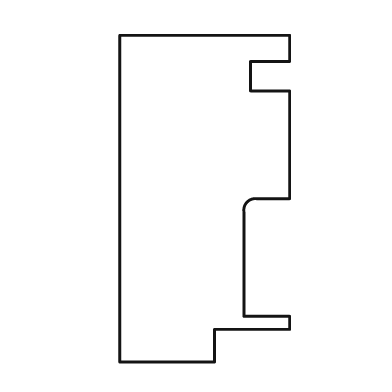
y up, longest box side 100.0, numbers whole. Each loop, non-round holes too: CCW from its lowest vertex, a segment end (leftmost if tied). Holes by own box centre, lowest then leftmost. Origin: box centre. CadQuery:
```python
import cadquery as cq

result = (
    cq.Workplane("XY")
    .moveTo(-26.0, -50.0)
    .lineTo(3.0, -50.0)
    .lineTo(3.0, -40.0)
    .lineTo(26.0, -40.0)
    .lineTo(26.0, -36.0)
    .lineTo(12.0, -36.0)
    .lineTo(12.0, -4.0)
    .threePointArc((13.0, -1.0), (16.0, 0.0))
    .lineTo(26.0, 0.0)
    .lineTo(26.0, 33.0)
    .lineTo(14.0, 33.0)
    .lineTo(14.0, 42.0)
    .lineTo(26.0, 42.0)
    .lineTo(26.0, 50.0)
    .lineTo(-26.0, 50.0)
    .close()
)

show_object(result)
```